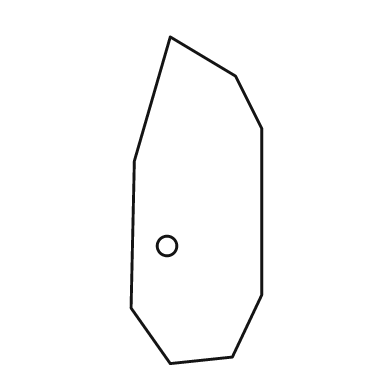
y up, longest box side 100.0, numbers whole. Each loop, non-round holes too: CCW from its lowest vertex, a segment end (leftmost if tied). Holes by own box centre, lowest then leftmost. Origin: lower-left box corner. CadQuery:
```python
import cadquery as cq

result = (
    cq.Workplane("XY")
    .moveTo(12.0, 0.0)
    .lineTo(31.0, 2.0)
    .lineTo(40.0, 21.0)
    .lineTo(40.0, 72.0)
    .lineTo(32.0, 88.0)
    .lineTo(12.0, 100.0)
    .lineTo(1.0, 62.0)
    .lineTo(0.0, 17.0)
    .close()
    .moveTo(11.0, 36.0)
    .circle(3.0)
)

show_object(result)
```